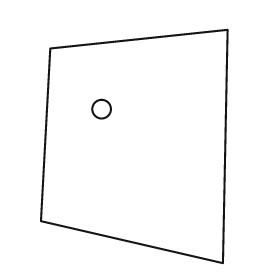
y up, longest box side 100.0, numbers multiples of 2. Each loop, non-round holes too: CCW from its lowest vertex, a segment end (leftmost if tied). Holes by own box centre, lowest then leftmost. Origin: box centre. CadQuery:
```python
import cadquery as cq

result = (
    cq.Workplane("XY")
    .moveTo(38.0, -50.0)
    .lineTo(40.0, 50.0)
    .lineTo(-36.0, 42.0)
    .lineTo(-40.0, -32.0)
    .close()
    .moveTo(-14.0, 16.0)
    .circle(4.0)
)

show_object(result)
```